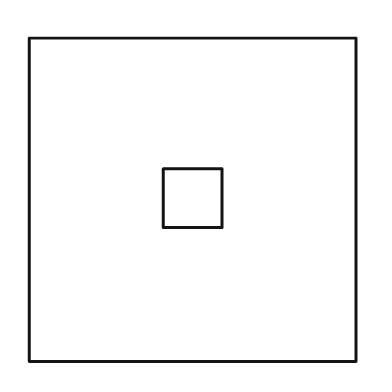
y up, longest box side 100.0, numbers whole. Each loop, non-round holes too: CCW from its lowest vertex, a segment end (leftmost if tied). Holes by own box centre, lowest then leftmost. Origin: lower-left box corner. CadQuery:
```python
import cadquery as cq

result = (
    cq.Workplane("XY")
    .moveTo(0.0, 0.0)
    .lineTo(100.0, 0.0)
    .lineTo(100.0, 99.0)
    .lineTo(0.0, 99.0)
    .close()
    .moveTo(41.0, 41.0)
    .lineTo(59.0, 41.0)
    .lineTo(59.0, 59.0)
    .lineTo(41.0, 59.0)
    .close()
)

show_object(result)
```